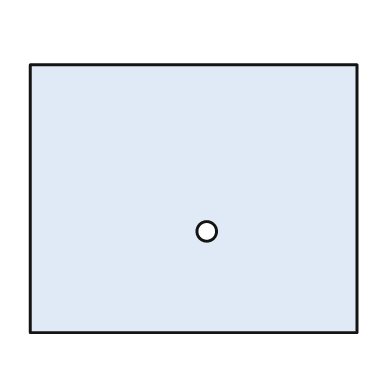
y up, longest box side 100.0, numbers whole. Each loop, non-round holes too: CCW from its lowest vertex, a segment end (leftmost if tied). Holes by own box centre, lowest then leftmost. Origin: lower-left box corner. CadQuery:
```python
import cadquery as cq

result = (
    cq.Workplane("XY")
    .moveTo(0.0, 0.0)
    .lineTo(100.0, 0.0)
    .lineTo(100.0, 82.0)
    .lineTo(0.0, 82.0)
    .close()
    .moveTo(54.0, 31.0)
    .circle(3.0)
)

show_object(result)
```